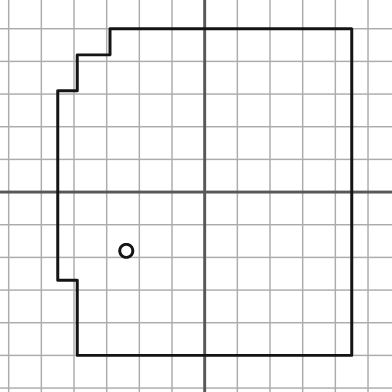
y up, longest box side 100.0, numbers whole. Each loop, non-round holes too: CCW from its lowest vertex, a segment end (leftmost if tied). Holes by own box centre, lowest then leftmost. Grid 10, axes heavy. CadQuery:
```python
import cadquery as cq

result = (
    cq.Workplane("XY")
    .moveTo(-39.0, -50.0)
    .lineTo(45.0, -50.0)
    .lineTo(45.0, 50.0)
    .lineTo(-29.0, 50.0)
    .lineTo(-29.0, 42.0)
    .lineTo(-39.0, 42.0)
    .lineTo(-39.0, 31.0)
    .lineTo(-45.0, 31.0)
    .lineTo(-45.0, -27.0)
    .lineTo(-39.0, -27.0)
    .close()
    .moveTo(-24.0, -18.0)
    .circle(2.0)
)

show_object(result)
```